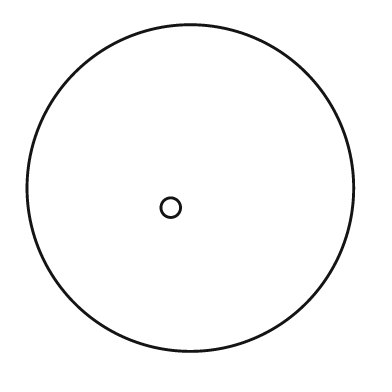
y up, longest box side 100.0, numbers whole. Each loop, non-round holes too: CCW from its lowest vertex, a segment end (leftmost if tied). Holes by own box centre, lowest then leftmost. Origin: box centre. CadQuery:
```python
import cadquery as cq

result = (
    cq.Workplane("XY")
    .moveTo(0.0, 0.0)
    .circle(50.0)
    .moveTo(-6.0, -6.0)
    .circle(3.0)
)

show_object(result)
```